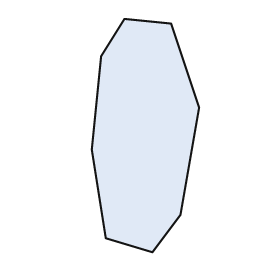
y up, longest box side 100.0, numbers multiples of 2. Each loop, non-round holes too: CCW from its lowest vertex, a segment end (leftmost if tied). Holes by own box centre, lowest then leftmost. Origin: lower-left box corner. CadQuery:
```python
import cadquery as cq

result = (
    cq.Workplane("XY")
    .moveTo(26.0, 0.0)
    .lineTo(38.0, 16.0)
    .lineTo(46.0, 62.0)
    .lineTo(34.0, 98.0)
    .lineTo(14.0, 100.0)
    .lineTo(4.0, 84.0)
    .lineTo(0.0, 44.0)
    .lineTo(6.0, 6.0)
    .close()
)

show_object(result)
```